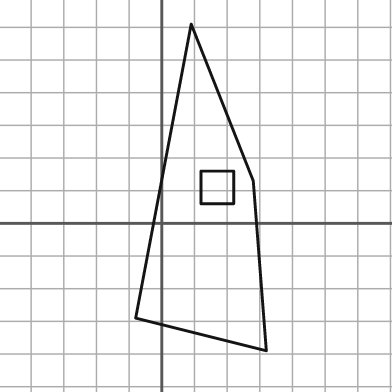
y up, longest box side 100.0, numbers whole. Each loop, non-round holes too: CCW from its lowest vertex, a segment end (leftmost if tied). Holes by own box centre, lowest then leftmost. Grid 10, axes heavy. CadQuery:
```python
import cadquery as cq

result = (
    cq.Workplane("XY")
    .moveTo(32.0, -39.0)
    .lineTo(28.0, 13.0)
    .lineTo(9.0, 61.0)
    .lineTo(-8.0, -29.0)
    .close()
    .moveTo(12.0, 6.0)
    .lineTo(22.0, 6.0)
    .lineTo(22.0, 16.0)
    .lineTo(12.0, 16.0)
    .close()
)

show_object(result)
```